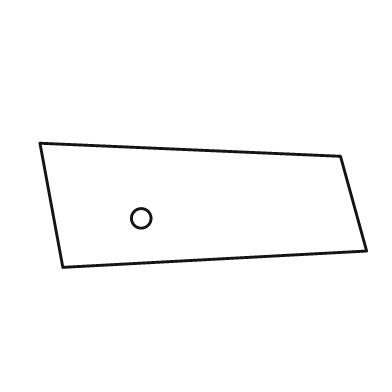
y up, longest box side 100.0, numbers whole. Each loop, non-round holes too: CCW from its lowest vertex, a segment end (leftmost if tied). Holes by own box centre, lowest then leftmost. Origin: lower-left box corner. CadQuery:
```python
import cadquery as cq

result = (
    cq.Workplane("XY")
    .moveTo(7.0, 0.0)
    .lineTo(100.0, 5.0)
    .lineTo(92.0, 34.0)
    .lineTo(0.0, 38.0)
    .close()
    .moveTo(31.0, 15.0)
    .circle(3.0)
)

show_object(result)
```